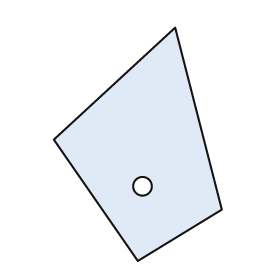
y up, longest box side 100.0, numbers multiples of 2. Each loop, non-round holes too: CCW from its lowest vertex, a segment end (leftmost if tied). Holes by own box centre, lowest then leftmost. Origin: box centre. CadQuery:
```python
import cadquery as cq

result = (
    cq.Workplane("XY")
    .moveTo(0.0, -50.0)
    .lineTo(36.0, -28.0)
    .lineTo(16.0, 50.0)
    .lineTo(-36.0, 2.0)
    .close()
    .moveTo(2.0, -18.0)
    .circle(4.0)
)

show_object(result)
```